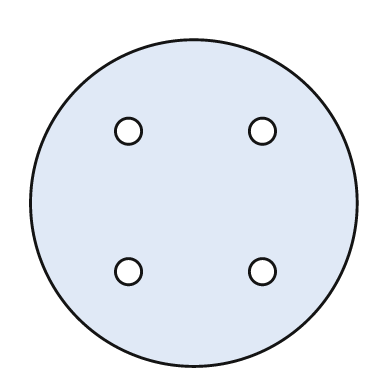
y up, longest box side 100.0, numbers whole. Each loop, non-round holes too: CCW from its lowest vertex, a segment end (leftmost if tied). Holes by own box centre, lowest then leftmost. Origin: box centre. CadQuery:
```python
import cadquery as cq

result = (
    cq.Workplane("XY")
    .moveTo(0.0, 0.0)
    .circle(50.0)
    .moveTo(-20.0, -21.0)
    .circle(4.0)
    .moveTo(21.0, -21.0)
    .circle(4.0)
    .moveTo(-20.0, 22.0)
    .circle(4.0)
    .moveTo(21.0, 22.0)
    .circle(4.0)
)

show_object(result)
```